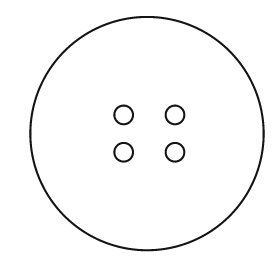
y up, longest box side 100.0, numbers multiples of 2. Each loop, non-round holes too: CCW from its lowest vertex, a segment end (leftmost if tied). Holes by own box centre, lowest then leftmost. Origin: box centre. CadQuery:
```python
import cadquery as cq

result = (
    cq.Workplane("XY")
    .moveTo(0.0, 0.0)
    .circle(50.0)
    .moveTo(-10.0, -8.0)
    .circle(4.0)
    .moveTo(12.0, -8.0)
    .circle(4.0)
    .moveTo(-10.0, 8.0)
    .circle(4.0)
    .moveTo(12.0, 8.0)
    .circle(4.0)
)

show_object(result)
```